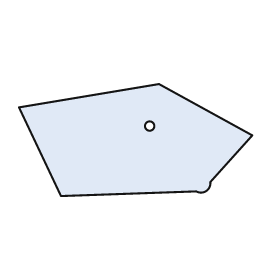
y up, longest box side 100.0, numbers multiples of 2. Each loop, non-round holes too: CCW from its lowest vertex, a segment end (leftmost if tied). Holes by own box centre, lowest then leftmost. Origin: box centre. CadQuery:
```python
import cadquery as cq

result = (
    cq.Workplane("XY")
    .moveTo(-32.0, -24.0)
    .lineTo(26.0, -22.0)
    .threePointArc((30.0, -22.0), (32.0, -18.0))
    .lineTo(50.0, 2.0)
    .lineTo(10.0, 24.0)
    .lineTo(-50.0, 14.0)
    .close()
    .moveTo(6.0, 6.0)
    .circle(2.0)
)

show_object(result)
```